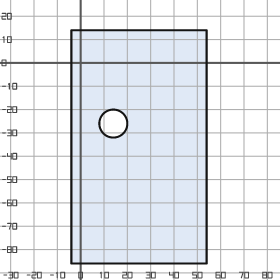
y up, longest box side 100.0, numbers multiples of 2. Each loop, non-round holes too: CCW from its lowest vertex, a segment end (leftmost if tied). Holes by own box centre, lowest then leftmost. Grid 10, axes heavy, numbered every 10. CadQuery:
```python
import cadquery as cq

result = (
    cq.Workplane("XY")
    .moveTo(-4.0, -86.0)
    .lineTo(54.0, -86.0)
    .lineTo(54.0, 14.0)
    .lineTo(-4.0, 14.0)
    .close()
    .moveTo(14.0, -26.0)
    .circle(6.0)
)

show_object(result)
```